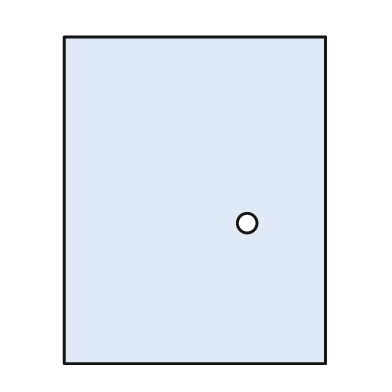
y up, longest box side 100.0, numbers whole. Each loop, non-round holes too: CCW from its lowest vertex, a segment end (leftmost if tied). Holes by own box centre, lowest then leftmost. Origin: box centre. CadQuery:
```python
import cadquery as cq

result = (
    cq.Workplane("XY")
    .moveTo(-40.0, -50.0)
    .lineTo(40.0, -50.0)
    .lineTo(40.0, 50.0)
    .lineTo(-40.0, 50.0)
    .close()
    .moveTo(16.0, -7.0)
    .circle(3.0)
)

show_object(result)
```